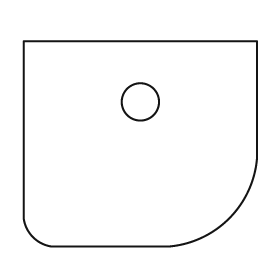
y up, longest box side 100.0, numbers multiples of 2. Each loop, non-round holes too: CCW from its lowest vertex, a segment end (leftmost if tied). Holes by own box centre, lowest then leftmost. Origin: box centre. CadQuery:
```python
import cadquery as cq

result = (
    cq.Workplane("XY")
    .moveTo(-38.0, -44.0)
    .lineTo(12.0, -44.0)
    .threePointArc((38.0, -32.0), (50.0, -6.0))
    .lineTo(50.0, 44.0)
    .lineTo(-50.0, 44.0)
    .lineTo(-50.0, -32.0)
    .threePointArc((-46.0, -40.0), (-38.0, -44.0))
    .close()
    .moveTo(0.0, 18.0)
    .circle(8.0)
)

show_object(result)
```